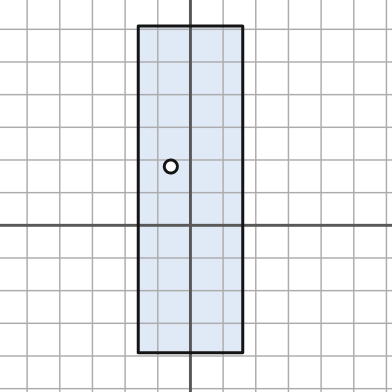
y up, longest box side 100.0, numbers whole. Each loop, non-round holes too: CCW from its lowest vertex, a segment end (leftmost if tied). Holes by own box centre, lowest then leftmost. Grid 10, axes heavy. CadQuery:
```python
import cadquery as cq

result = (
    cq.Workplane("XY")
    .moveTo(-16.0, -39.0)
    .lineTo(16.0, -39.0)
    .lineTo(16.0, 61.0)
    .lineTo(-16.0, 61.0)
    .close()
    .moveTo(-6.0, 18.0)
    .circle(2.0)
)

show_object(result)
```